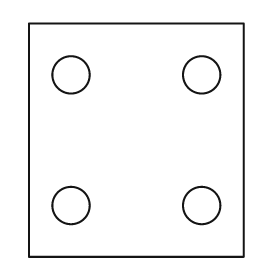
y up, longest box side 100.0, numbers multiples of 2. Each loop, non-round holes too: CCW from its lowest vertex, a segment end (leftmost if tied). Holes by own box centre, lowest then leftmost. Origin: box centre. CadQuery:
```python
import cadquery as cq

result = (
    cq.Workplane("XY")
    .moveTo(-46.0, -50.0)
    .lineTo(46.0, -50.0)
    .lineTo(46.0, 50.0)
    .lineTo(-46.0, 50.0)
    .close()
    .moveTo(-28.0, -28.0)
    .circle(8.0)
    .moveTo(28.0, -28.0)
    .circle(8.0)
    .moveTo(-28.0, 28.0)
    .circle(8.0)
    .moveTo(28.0, 28.0)
    .circle(8.0)
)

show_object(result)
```